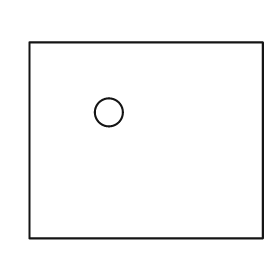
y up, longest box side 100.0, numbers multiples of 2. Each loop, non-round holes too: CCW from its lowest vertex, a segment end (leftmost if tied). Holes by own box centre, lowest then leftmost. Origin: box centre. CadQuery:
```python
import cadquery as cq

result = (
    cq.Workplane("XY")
    .moveTo(-50.0, -42.0)
    .lineTo(50.0, -42.0)
    .lineTo(50.0, 42.0)
    .lineTo(-50.0, 42.0)
    .close()
    .moveTo(-16.0, 12.0)
    .circle(6.0)
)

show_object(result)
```